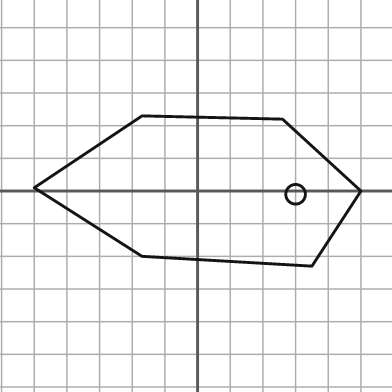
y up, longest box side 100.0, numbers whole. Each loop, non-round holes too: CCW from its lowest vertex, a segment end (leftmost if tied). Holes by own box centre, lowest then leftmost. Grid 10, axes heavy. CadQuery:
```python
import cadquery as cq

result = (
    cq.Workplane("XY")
    .moveTo(35.0, -23.0)
    .lineTo(50.0, 0.0)
    .lineTo(26.0, 22.0)
    .lineTo(-17.0, 23.0)
    .lineTo(-50.0, 1.0)
    .lineTo(-17.0, -20.0)
    .close()
    .moveTo(30.0, -1.0)
    .circle(3.0)
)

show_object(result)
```